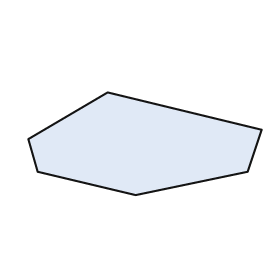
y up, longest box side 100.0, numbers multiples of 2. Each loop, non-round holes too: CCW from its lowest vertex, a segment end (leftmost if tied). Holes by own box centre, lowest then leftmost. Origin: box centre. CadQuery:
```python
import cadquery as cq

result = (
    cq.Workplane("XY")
    .moveTo(-4.0, -22.0)
    .lineTo(44.0, -12.0)
    .lineTo(50.0, 6.0)
    .lineTo(-16.0, 22.0)
    .lineTo(-50.0, 2.0)
    .lineTo(-46.0, -12.0)
    .close()
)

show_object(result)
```